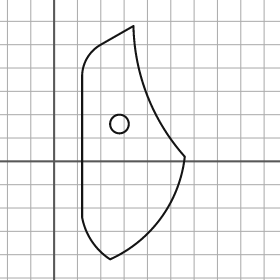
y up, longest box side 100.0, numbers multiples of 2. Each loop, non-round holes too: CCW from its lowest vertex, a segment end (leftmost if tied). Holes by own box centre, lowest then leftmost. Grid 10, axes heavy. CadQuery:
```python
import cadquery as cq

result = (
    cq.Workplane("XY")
    .moveTo(24.0, -42.0)
    .threePointArc((46.0, -24.0), (56.0, 2.0))
    .threePointArc((40.0, 28.0), (34.0, 58.0))
    .lineTo(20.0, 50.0)
    .threePointArc((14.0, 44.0), (12.0, 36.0))
    .lineTo(12.0, -24.0)
    .threePointArc((16.0, -34.0), (24.0, -42.0))
    .close()
    .moveTo(28.0, 16.0)
    .circle(4.0)
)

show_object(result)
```